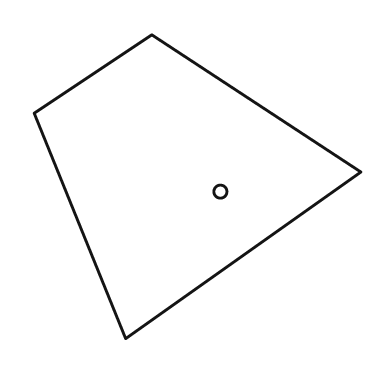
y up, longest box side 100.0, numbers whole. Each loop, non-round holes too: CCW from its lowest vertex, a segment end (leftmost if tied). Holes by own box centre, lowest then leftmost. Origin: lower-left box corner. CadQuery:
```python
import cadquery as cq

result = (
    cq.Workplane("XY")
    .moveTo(28.0, 0.0)
    .lineTo(100.0, 51.0)
    .lineTo(36.0, 93.0)
    .lineTo(0.0, 69.0)
    .close()
    .moveTo(57.0, 45.0)
    .circle(2.0)
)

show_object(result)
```